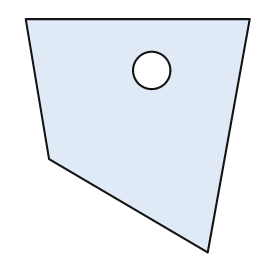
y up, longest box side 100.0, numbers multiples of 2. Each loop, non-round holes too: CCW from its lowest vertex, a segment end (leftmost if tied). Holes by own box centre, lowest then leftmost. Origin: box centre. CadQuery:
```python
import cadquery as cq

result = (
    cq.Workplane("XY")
    .moveTo(30.0, -50.0)
    .lineTo(48.0, 50.0)
    .lineTo(-48.0, 50.0)
    .lineTo(-38.0, -10.0)
    .close()
    .moveTo(6.0, 28.0)
    .circle(8.0)
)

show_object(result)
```